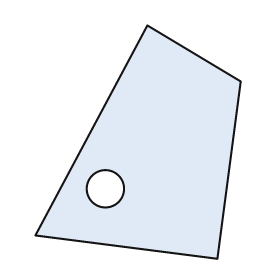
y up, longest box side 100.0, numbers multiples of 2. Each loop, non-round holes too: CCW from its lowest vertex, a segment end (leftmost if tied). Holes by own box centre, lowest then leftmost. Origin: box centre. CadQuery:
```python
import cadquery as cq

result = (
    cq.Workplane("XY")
    .moveTo(34.0, -50.0)
    .lineTo(44.0, 26.0)
    .lineTo(4.0, 50.0)
    .lineTo(-44.0, -40.0)
    .close()
    .moveTo(-14.0, -20.0)
    .circle(8.0)
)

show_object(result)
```